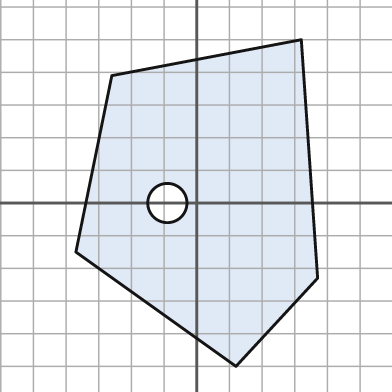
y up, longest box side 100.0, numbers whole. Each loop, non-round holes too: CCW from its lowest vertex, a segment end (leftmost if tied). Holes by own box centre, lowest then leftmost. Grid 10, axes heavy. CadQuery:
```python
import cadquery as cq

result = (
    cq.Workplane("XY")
    .moveTo(12.0, -50.0)
    .lineTo(37.0, -23.0)
    .lineTo(32.0, 50.0)
    .lineTo(-26.0, 39.0)
    .lineTo(-37.0, -15.0)
    .close()
    .moveTo(-9.0, 0.0)
    .circle(6.0)
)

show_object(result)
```